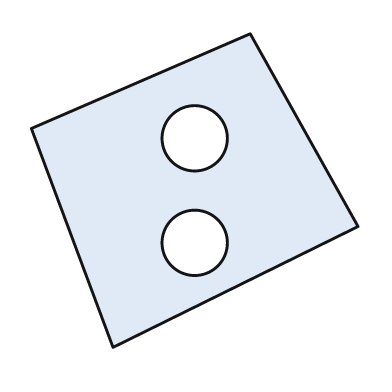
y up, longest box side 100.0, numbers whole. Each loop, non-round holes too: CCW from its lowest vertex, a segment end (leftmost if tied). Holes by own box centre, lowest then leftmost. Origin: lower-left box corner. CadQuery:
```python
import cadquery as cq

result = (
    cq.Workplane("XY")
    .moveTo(25.0, 0.0)
    .lineTo(100.0, 37.0)
    .lineTo(67.0, 96.0)
    .lineTo(0.0, 67.0)
    .close()
    .moveTo(50.0, 32.0)
    .circle(10.0)
    .moveTo(50.0, 64.0)
    .circle(10.0)
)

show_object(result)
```